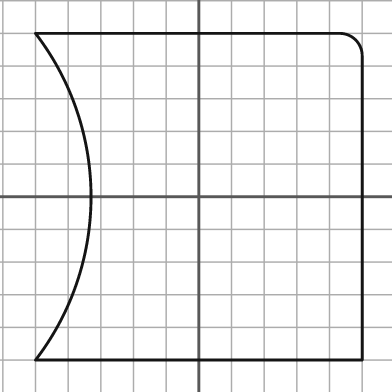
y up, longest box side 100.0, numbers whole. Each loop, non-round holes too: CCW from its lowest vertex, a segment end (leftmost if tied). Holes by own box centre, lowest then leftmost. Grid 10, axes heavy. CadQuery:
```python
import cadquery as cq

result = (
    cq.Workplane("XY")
    .moveTo(-50.0, -50.0)
    .lineTo(50.0, -50.0)
    .lineTo(50.0, 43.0)
    .threePointArc((48.0, 48.0), (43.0, 50.0))
    .lineTo(-50.0, 50.0)
    .threePointArc((-33.0, 0.0), (-50.0, -50.0))
    .close()
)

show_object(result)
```